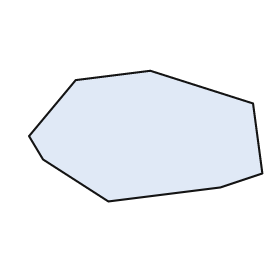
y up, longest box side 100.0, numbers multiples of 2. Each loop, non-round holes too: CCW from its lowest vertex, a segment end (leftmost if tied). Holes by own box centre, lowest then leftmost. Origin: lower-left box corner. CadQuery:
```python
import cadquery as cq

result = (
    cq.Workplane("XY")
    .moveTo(34.0, 0.0)
    .lineTo(82.0, 6.0)
    .lineTo(100.0, 12.0)
    .lineTo(96.0, 42.0)
    .lineTo(52.0, 56.0)
    .lineTo(20.0, 52.0)
    .lineTo(0.0, 28.0)
    .lineTo(6.0, 18.0)
    .close()
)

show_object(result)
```